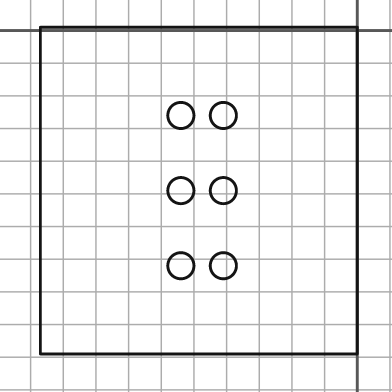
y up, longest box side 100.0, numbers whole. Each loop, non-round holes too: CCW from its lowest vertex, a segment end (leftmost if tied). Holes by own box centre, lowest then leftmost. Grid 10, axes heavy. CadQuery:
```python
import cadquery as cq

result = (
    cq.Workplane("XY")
    .moveTo(-97.0, -99.0)
    .lineTo(0.0, -99.0)
    .lineTo(0.0, 1.0)
    .lineTo(-97.0, 1.0)
    .close()
    .moveTo(-54.0, -72.0)
    .circle(4.0)
    .moveTo(-41.0, -72.0)
    .circle(4.0)
    .moveTo(-54.0, -49.0)
    .circle(4.0)
    .moveTo(-41.0, -49.0)
    .circle(4.0)
    .moveTo(-54.0, -26.0)
    .circle(4.0)
    .moveTo(-41.0, -26.0)
    .circle(4.0)
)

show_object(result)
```